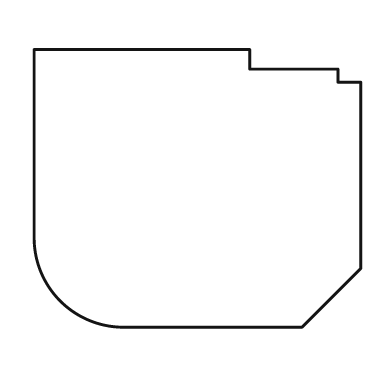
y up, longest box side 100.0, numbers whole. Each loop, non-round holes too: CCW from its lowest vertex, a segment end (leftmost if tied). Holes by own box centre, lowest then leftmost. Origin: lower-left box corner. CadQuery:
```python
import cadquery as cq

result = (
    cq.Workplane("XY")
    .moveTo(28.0, 0.0)
    .lineTo(82.0, 0.0)
    .lineTo(100.0, 18.0)
    .lineTo(100.0, 75.0)
    .lineTo(93.0, 75.0)
    .lineTo(93.0, 79.0)
    .lineTo(66.0, 79.0)
    .lineTo(66.0, 85.0)
    .lineTo(0.0, 85.0)
    .lineTo(0.0, 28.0)
    .threePointArc((8.0, 8.0), (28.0, 0.0))
    .close()
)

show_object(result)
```